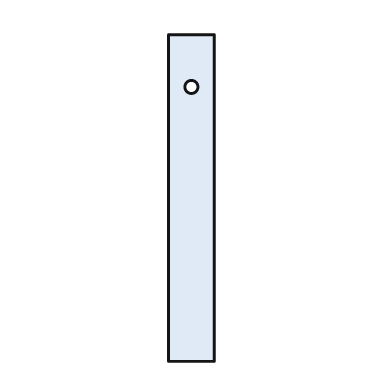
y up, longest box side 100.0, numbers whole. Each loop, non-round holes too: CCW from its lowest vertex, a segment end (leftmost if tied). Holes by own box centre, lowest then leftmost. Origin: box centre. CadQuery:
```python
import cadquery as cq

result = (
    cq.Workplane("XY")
    .moveTo(-7.0, -50.0)
    .lineTo(7.0, -50.0)
    .lineTo(7.0, 50.0)
    .lineTo(-7.0, 50.0)
    .close()
    .moveTo(0.0, 34.0)
    .circle(2.0)
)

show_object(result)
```